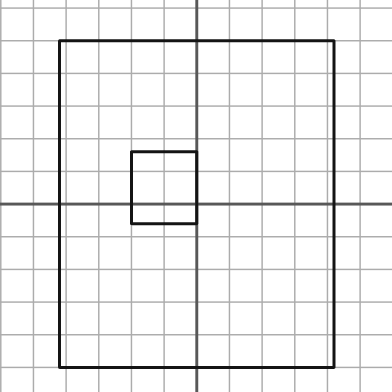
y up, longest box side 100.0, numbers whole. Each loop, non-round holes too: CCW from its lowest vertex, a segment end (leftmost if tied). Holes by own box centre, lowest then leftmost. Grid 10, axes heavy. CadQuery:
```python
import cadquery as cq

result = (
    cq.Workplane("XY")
    .moveTo(-42.0, -50.0)
    .lineTo(42.0, -50.0)
    .lineTo(42.0, 50.0)
    .lineTo(-42.0, 50.0)
    .close()
    .moveTo(-20.0, -6.0)
    .lineTo(0.0, -6.0)
    .lineTo(0.0, 16.0)
    .lineTo(-20.0, 16.0)
    .close()
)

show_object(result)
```